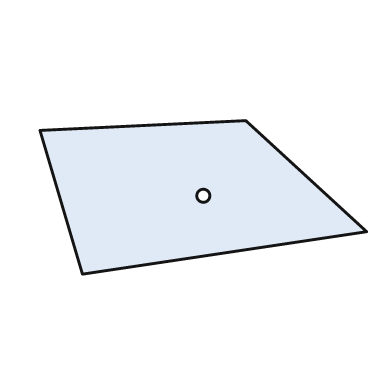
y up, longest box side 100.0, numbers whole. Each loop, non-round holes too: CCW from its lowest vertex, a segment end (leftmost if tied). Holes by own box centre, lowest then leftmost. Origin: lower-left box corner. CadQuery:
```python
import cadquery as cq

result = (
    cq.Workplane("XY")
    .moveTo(13.0, 0.0)
    .lineTo(100.0, 13.0)
    .lineTo(63.0, 47.0)
    .lineTo(0.0, 44.0)
    .close()
    .moveTo(50.0, 24.0)
    .circle(2.0)
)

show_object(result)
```